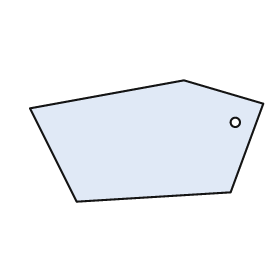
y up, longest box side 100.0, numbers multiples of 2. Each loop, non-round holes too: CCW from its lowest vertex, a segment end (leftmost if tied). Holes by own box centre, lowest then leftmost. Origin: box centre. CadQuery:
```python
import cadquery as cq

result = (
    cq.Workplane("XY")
    .moveTo(-30.0, -26.0)
    .lineTo(36.0, -22.0)
    .lineTo(50.0, 16.0)
    .lineTo(16.0, 26.0)
    .lineTo(-50.0, 14.0)
    .close()
    .moveTo(38.0, 8.0)
    .circle(2.0)
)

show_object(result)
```